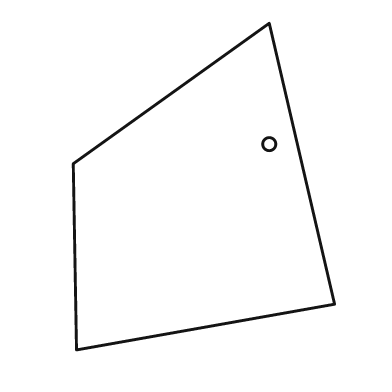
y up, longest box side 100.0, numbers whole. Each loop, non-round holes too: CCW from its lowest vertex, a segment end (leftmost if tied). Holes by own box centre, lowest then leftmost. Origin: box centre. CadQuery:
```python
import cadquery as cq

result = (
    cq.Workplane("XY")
    .moveTo(-39.0, -50.0)
    .lineTo(40.0, -36.0)
    .lineTo(20.0, 50.0)
    .lineTo(-40.0, 7.0)
    .close()
    .moveTo(20.0, 13.0)
    .circle(2.0)
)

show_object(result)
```